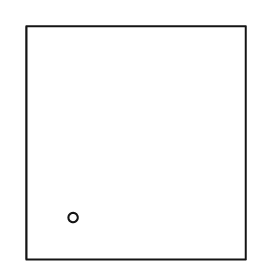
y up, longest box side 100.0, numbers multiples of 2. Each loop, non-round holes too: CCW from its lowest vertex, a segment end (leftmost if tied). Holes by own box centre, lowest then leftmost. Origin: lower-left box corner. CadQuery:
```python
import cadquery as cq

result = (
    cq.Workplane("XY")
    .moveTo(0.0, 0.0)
    .lineTo(94.0, 0.0)
    .lineTo(94.0, 100.0)
    .lineTo(0.0, 100.0)
    .close()
    .moveTo(20.0, 18.0)
    .circle(2.0)
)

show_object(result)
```